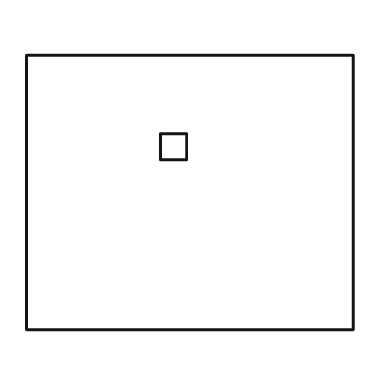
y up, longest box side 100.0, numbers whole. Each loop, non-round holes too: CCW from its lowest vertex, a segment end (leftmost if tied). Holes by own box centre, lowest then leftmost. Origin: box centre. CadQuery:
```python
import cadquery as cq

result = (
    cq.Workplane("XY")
    .moveTo(-50.0, -42.0)
    .lineTo(50.0, -42.0)
    .lineTo(50.0, 42.0)
    .lineTo(-50.0, 42.0)
    .close()
    .moveTo(-9.0, 10.0)
    .lineTo(-1.0, 10.0)
    .lineTo(-1.0, 18.0)
    .lineTo(-9.0, 18.0)
    .close()
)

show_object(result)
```